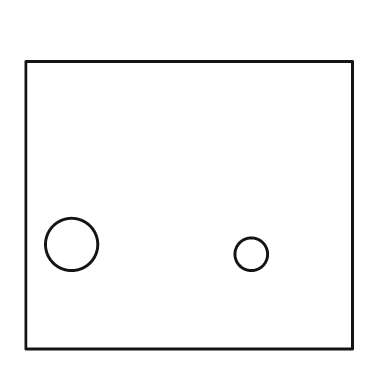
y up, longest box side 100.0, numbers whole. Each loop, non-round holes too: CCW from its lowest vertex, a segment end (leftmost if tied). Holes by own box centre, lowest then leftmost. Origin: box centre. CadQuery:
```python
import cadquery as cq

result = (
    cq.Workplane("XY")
    .moveTo(-50.0, -44.0)
    .lineTo(50.0, -44.0)
    .lineTo(50.0, 44.0)
    .lineTo(-50.0, 44.0)
    .close()
    .moveTo(19.0, -15.0)
    .circle(5.0)
    .moveTo(-36.0, -12.0)
    .circle(8.0)
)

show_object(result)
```